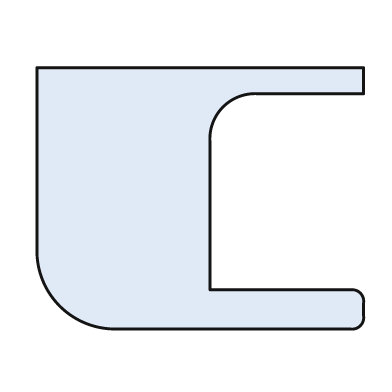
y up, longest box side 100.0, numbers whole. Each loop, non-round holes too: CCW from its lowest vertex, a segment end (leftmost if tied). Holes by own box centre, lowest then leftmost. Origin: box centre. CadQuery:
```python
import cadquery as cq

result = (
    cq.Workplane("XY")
    .moveTo(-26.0, -40.0)
    .lineTo(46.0, -40.0)
    .threePointArc((49.0, -39.0), (50.0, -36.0))
    .lineTo(50.0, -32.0)
    .threePointArc((49.0, -29.0), (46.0, -28.0))
    .lineTo(3.0, -28.0)
    .lineTo(3.0, 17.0)
    .threePointArc((7.0, 28.0), (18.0, 32.0))
    .lineTo(50.0, 32.0)
    .lineTo(50.0, 40.0)
    .lineTo(-50.0, 40.0)
    .lineTo(-50.0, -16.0)
    .threePointArc((-43.0, -33.0), (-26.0, -40.0))
    .close()
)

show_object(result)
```